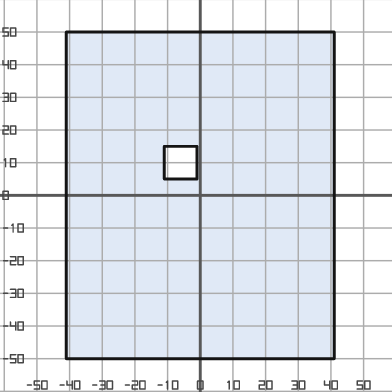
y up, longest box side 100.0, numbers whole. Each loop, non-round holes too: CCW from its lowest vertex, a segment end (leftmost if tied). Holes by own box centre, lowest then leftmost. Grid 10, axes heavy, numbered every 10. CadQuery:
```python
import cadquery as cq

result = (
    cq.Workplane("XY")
    .moveTo(-41.0, -50.0)
    .lineTo(41.0, -50.0)
    .lineTo(41.0, 50.0)
    .lineTo(-41.0, 50.0)
    .close()
    .moveTo(-11.0, 5.0)
    .lineTo(-1.0, 5.0)
    .lineTo(-1.0, 15.0)
    .lineTo(-11.0, 15.0)
    .close()
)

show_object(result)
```